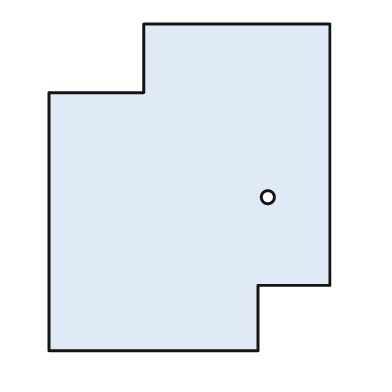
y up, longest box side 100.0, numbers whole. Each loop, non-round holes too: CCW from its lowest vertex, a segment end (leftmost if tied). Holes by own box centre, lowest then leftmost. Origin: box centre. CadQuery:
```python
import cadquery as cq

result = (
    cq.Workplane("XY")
    .moveTo(-43.0, -50.0)
    .lineTo(21.0, -50.0)
    .lineTo(21.0, -30.0)
    .lineTo(43.0, -30.0)
    .lineTo(43.0, 50.0)
    .lineTo(-14.0, 50.0)
    .lineTo(-14.0, 29.0)
    .lineTo(-43.0, 29.0)
    .close()
    .moveTo(24.0, -3.0)
    .circle(2.0)
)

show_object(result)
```